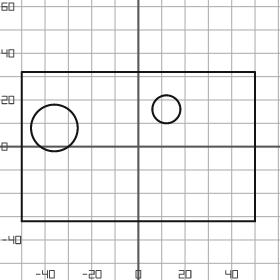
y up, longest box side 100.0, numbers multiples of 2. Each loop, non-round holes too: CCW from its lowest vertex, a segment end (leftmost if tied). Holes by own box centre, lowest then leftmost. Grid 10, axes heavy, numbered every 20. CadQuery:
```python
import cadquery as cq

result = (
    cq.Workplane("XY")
    .moveTo(-50.0, -32.0)
    .lineTo(50.0, -32.0)
    .lineTo(50.0, 32.0)
    .lineTo(-50.0, 32.0)
    .close()
    .moveTo(-36.0, 8.0)
    .circle(10.0)
    .moveTo(12.0, 16.0)
    .circle(6.0)
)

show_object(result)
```